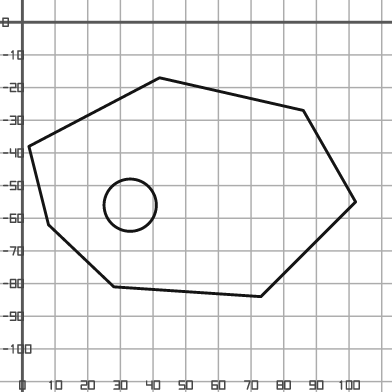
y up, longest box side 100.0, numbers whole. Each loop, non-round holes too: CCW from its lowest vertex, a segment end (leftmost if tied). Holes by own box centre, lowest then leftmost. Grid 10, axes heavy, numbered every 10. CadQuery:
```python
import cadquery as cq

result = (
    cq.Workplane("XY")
    .moveTo(73.0, -84.0)
    .lineTo(102.0, -55.0)
    .lineTo(86.0, -27.0)
    .lineTo(42.0, -17.0)
    .lineTo(2.0, -38.0)
    .lineTo(8.0, -62.0)
    .lineTo(28.0, -81.0)
    .close()
    .moveTo(33.0, -56.0)
    .circle(8.0)
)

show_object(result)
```